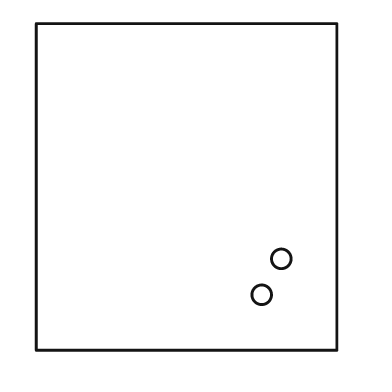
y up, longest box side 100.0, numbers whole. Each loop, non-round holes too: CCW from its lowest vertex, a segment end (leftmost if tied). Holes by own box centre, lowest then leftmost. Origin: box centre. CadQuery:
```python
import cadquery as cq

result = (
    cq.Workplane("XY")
    .moveTo(-46.0, -50.0)
    .lineTo(46.0, -50.0)
    .lineTo(46.0, 50.0)
    .lineTo(-46.0, 50.0)
    .close()
    .moveTo(23.0, -33.0)
    .circle(3.0)
    .moveTo(29.0, -22.0)
    .circle(3.0)
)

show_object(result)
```